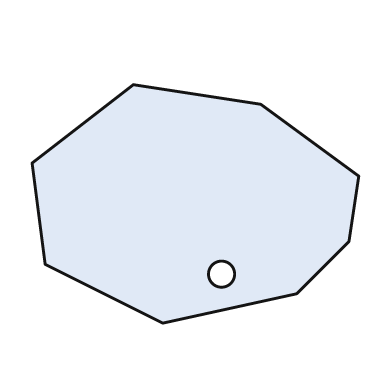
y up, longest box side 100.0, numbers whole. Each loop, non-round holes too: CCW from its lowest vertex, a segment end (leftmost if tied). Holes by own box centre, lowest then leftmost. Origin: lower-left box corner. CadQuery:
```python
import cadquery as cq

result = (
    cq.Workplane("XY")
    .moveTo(40.0, 0.0)
    .lineTo(81.0, 9.0)
    .lineTo(97.0, 25.0)
    .lineTo(100.0, 45.0)
    .lineTo(70.0, 67.0)
    .lineTo(31.0, 73.0)
    .lineTo(0.0, 49.0)
    .lineTo(4.0, 18.0)
    .close()
    .moveTo(58.0, 15.0)
    .circle(4.0)
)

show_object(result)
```